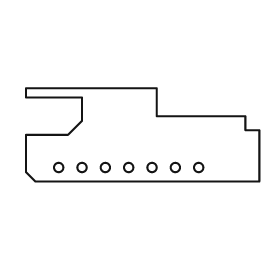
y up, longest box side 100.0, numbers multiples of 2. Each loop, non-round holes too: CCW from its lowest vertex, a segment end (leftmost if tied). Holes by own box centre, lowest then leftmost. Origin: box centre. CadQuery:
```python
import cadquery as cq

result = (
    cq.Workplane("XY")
    .moveTo(-46.0, -20.0)
    .lineTo(50.0, -20.0)
    .lineTo(50.0, 2.0)
    .lineTo(44.0, 2.0)
    .lineTo(44.0, 8.0)
    .lineTo(6.0, 8.0)
    .lineTo(6.0, 20.0)
    .lineTo(-50.0, 20.0)
    .lineTo(-50.0, 16.0)
    .lineTo(-26.0, 16.0)
    .lineTo(-26.0, 6.0)
    .lineTo(-32.0, 0.0)
    .lineTo(-50.0, 0.0)
    .lineTo(-50.0, -16.0)
    .close()
    .moveTo(-36.0, -14.0)
    .circle(2.0)
    .moveTo(-26.0, -14.0)
    .circle(2.0)
    .moveTo(-16.0, -14.0)
    .circle(2.0)
    .moveTo(-6.0, -14.0)
    .circle(2.0)
    .moveTo(4.0, -14.0)
    .circle(2.0)
    .moveTo(14.0, -14.0)
    .circle(2.0)
    .moveTo(24.0, -14.0)
    .circle(2.0)
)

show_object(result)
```